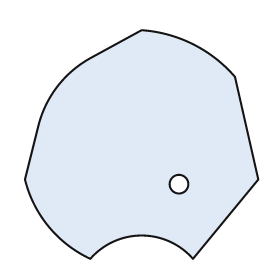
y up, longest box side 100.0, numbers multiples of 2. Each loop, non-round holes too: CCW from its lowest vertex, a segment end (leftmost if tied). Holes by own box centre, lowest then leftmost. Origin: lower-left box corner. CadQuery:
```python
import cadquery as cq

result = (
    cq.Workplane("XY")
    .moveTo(28.0, 0.0)
    .threePointArc((50.0, 10.0), (72.0, 0.0))
    .lineTo(100.0, 34.0)
    .lineTo(90.0, 78.0)
    .threePointArc((72.0, 92.0), (50.0, 98.0))
    .lineTo(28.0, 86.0)
    .threePointArc((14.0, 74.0), (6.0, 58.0))
    .lineTo(0.0, 34.0)
    .threePointArc((10.0, 14.0), (28.0, 0.0))
    .close()
    .moveTo(66.0, 32.0)
    .circle(4.0)
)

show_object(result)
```